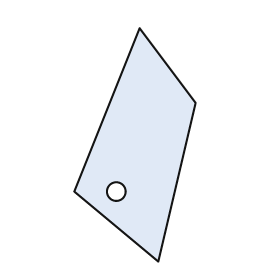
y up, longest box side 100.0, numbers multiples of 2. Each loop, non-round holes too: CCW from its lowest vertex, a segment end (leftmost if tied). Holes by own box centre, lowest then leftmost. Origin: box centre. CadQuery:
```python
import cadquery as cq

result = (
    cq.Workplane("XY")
    .moveTo(10.0, -50.0)
    .lineTo(26.0, 18.0)
    .lineTo(2.0, 50.0)
    .lineTo(-26.0, -20.0)
    .close()
    .moveTo(-8.0, -20.0)
    .circle(4.0)
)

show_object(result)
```